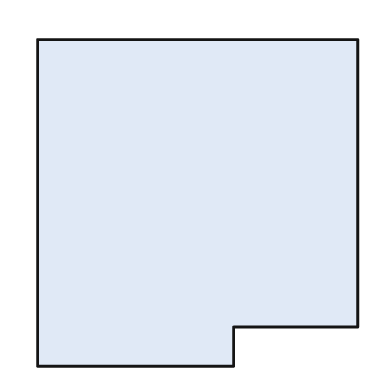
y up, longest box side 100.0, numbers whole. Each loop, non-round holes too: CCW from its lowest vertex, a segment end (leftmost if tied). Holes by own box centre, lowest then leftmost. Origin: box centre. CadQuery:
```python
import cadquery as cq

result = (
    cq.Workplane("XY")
    .moveTo(-49.0, -50.0)
    .lineTo(11.0, -50.0)
    .lineTo(11.0, -38.0)
    .lineTo(49.0, -38.0)
    .lineTo(49.0, 50.0)
    .lineTo(-49.0, 50.0)
    .close()
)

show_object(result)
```